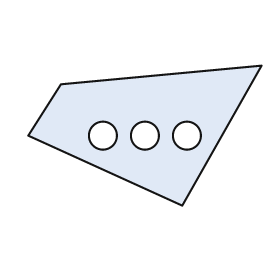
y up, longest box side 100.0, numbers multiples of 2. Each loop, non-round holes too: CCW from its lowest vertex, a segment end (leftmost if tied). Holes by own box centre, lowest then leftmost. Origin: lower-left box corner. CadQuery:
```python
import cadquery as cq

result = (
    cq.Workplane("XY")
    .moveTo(66.0, 0.0)
    .lineTo(100.0, 60.0)
    .lineTo(14.0, 52.0)
    .lineTo(0.0, 30.0)
    .close()
    .moveTo(32.0, 30.0)
    .circle(6.0)
    .moveTo(50.0, 30.0)
    .circle(6.0)
    .moveTo(68.0, 30.0)
    .circle(6.0)
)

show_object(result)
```